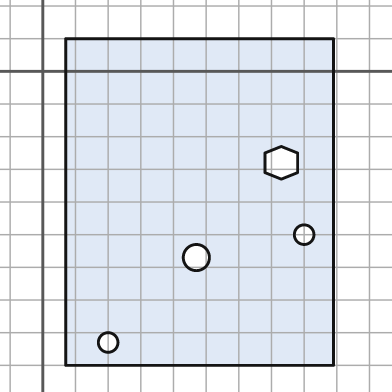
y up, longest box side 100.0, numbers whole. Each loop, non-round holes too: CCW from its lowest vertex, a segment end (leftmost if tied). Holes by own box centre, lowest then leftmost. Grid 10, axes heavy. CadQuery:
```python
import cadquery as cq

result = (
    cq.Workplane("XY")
    .moveTo(7.0, -90.0)
    .lineTo(89.0, -90.0)
    .lineTo(89.0, 10.0)
    .lineTo(7.0, 10.0)
    .close()
    .moveTo(20.0, -83.0)
    .circle(3.0)
    .moveTo(47.0, -57.0)
    .circle(4.0)
    .moveTo(80.0, -50.0)
    .circle(3.0)
    .moveTo(73.0, -33.0)
    .lineTo(78.0, -31.0)
    .lineTo(78.0, -25.0)
    .lineTo(73.0, -23.0)
    .lineTo(68.0, -25.0)
    .lineTo(68.0, -31.0)
    .close()
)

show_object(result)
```